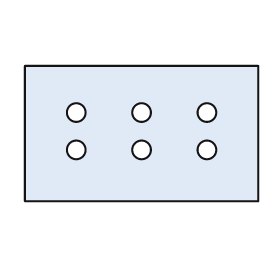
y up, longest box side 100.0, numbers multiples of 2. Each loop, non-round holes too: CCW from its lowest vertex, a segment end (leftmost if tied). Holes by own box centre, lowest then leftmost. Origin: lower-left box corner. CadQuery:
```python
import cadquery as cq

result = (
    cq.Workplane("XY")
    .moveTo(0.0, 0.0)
    .lineTo(100.0, 0.0)
    .lineTo(100.0, 58.0)
    .lineTo(0.0, 58.0)
    .close()
    .moveTo(22.0, 22.0)
    .circle(4.0)
    .moveTo(50.0, 22.0)
    .circle(4.0)
    .moveTo(78.0, 22.0)
    .circle(4.0)
    .moveTo(22.0, 38.0)
    .circle(4.0)
    .moveTo(50.0, 38.0)
    .circle(4.0)
    .moveTo(78.0, 38.0)
    .circle(4.0)
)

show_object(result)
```